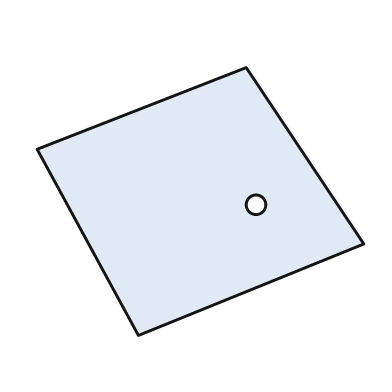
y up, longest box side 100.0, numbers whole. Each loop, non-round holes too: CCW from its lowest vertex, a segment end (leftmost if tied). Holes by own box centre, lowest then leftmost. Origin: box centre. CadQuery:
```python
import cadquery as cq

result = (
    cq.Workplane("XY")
    .moveTo(-19.0, -41.0)
    .lineTo(50.0, -13.0)
    .lineTo(14.0, 41.0)
    .lineTo(-50.0, 16.0)
    .close()
    .moveTo(17.0, -1.0)
    .circle(3.0)
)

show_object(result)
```